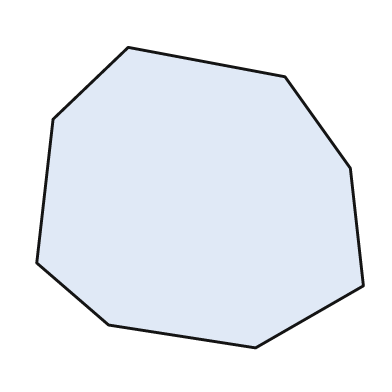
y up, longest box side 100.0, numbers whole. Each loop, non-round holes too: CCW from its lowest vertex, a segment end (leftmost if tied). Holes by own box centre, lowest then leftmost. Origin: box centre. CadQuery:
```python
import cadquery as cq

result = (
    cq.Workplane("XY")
    .moveTo(17.0, -46.0)
    .lineTo(50.0, -27.0)
    .lineTo(46.0, 9.0)
    .lineTo(26.0, 37.0)
    .lineTo(-22.0, 46.0)
    .lineTo(-45.0, 24.0)
    .lineTo(-50.0, -20.0)
    .lineTo(-28.0, -39.0)
    .close()
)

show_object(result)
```